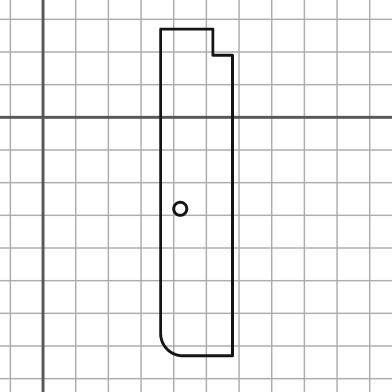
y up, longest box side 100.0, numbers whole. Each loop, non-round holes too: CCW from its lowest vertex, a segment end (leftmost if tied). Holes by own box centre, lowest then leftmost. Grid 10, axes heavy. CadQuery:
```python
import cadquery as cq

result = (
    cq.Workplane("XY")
    .moveTo(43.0, -73.0)
    .lineTo(58.0, -73.0)
    .lineTo(58.0, 19.0)
    .lineTo(52.0, 19.0)
    .lineTo(52.0, 27.0)
    .lineTo(36.0, 27.0)
    .lineTo(36.0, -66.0)
    .threePointArc((38.0, -71.0), (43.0, -73.0))
    .close()
    .moveTo(42.0, -28.0)
    .circle(2.0)
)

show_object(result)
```